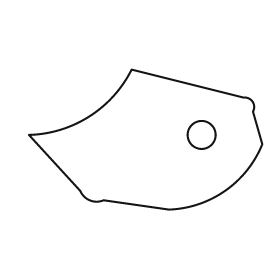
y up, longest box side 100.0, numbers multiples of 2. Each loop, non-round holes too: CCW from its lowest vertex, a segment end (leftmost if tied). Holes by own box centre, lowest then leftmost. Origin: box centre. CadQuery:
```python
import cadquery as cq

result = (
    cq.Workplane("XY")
    .moveTo(10.0, -30.0)
    .threePointArc((34.0, -22.0), (50.0, -2.0))
    .lineTo(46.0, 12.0)
    .threePointArc((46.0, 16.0), (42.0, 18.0))
    .lineTo(-6.0, 30.0)
    .threePointArc((-24.0, 10.0), (-50.0, 2.0))
    .lineTo(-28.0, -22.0)
    .threePointArc((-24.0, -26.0), (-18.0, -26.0))
    .close()
    .moveTo(24.0, 2.0)
    .circle(6.0)
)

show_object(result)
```